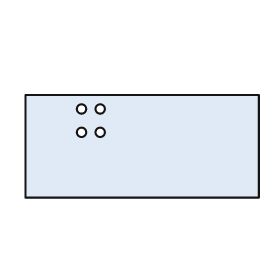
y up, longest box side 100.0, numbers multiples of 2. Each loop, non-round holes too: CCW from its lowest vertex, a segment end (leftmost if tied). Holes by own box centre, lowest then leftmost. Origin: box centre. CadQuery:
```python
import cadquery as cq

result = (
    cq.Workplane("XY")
    .moveTo(-50.0, -22.0)
    .lineTo(50.0, -22.0)
    .lineTo(50.0, 22.0)
    .lineTo(-50.0, 22.0)
    .close()
    .moveTo(-26.0, 6.0)
    .circle(2.0)
    .moveTo(-18.0, 6.0)
    .circle(2.0)
    .moveTo(-26.0, 16.0)
    .circle(2.0)
    .moveTo(-18.0, 16.0)
    .circle(2.0)
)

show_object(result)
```